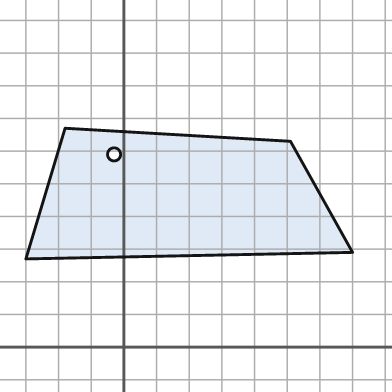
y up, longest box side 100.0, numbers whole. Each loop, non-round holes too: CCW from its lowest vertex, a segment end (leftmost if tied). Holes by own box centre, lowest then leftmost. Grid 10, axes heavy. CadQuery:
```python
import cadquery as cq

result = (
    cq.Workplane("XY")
    .moveTo(-30.0, 27.0)
    .lineTo(70.0, 29.0)
    .lineTo(51.0, 63.0)
    .lineTo(-18.0, 67.0)
    .close()
    .moveTo(-3.0, 59.0)
    .circle(2.0)
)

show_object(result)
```